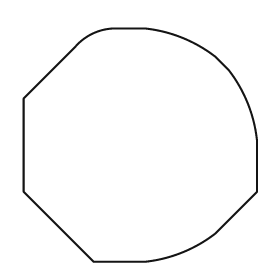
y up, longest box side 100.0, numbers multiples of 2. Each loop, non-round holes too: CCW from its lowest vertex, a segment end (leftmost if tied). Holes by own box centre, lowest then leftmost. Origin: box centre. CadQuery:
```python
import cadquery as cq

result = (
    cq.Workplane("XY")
    .moveTo(-20.0, -50.0)
    .lineTo(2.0, -50.0)
    .threePointArc((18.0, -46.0), (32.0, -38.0))
    .lineTo(50.0, -20.0)
    .lineTo(50.0, 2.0)
    .threePointArc((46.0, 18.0), (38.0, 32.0))
    .lineTo(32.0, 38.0)
    .threePointArc((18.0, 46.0), (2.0, 50.0))
    .lineTo(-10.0, 50.0)
    .threePointArc((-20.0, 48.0), (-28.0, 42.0))
    .lineTo(-50.0, 20.0)
    .lineTo(-50.0, -20.0)
    .close()
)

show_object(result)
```